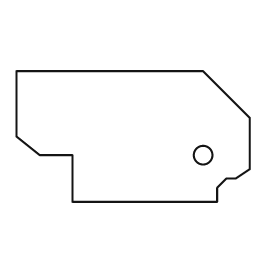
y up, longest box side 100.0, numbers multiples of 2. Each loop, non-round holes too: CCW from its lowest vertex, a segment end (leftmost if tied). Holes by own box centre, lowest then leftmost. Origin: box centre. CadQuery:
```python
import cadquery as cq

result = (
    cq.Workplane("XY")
    .moveTo(-26.0, -28.0)
    .lineTo(36.0, -28.0)
    .lineTo(36.0, -22.0)
    .lineTo(40.0, -18.0)
    .lineTo(44.0, -18.0)
    .lineTo(50.0, -14.0)
    .lineTo(50.0, 8.0)
    .lineTo(30.0, 28.0)
    .lineTo(-50.0, 28.0)
    .lineTo(-50.0, 0.0)
    .lineTo(-40.0, -8.0)
    .lineTo(-26.0, -8.0)
    .close()
    .moveTo(30.0, -8.0)
    .circle(4.0)
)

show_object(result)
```